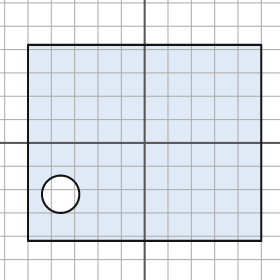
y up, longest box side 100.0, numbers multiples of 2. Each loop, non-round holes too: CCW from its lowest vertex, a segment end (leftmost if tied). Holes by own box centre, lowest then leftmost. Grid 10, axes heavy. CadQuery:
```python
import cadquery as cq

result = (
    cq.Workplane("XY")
    .moveTo(-50.0, -42.0)
    .lineTo(50.0, -42.0)
    .lineTo(50.0, 42.0)
    .lineTo(-50.0, 42.0)
    .close()
    .moveTo(-36.0, -22.0)
    .circle(8.0)
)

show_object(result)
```